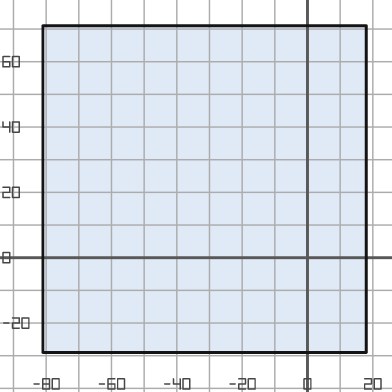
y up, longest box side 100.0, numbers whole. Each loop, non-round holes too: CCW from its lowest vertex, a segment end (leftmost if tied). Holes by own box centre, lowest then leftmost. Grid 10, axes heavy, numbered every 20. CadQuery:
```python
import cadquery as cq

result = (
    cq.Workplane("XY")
    .moveTo(-81.0, -29.0)
    .lineTo(18.0, -29.0)
    .lineTo(18.0, 71.0)
    .lineTo(-81.0, 71.0)
    .close()
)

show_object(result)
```